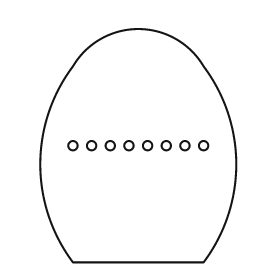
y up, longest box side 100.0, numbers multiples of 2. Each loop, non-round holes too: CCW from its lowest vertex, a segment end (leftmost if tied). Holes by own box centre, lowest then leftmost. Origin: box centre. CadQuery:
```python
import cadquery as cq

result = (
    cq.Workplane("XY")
    .moveTo(-28.0, -50.0)
    .lineTo(28.0, -50.0)
    .threePointArc((42.0, -8.0), (28.0, 34.0))
    .threePointArc((0.0, 50.0), (-28.0, 34.0))
    .threePointArc((-42.0, -8.0), (-28.0, -50.0))
    .close()
    .moveTo(-28.0, 0.0)
    .circle(2.0)
    .moveTo(-20.0, 0.0)
    .circle(2.0)
    .moveTo(-12.0, 0.0)
    .circle(2.0)
    .moveTo(-4.0, 0.0)
    .circle(2.0)
    .moveTo(4.0, 0.0)
    .circle(2.0)
    .moveTo(12.0, 0.0)
    .circle(2.0)
    .moveTo(20.0, 0.0)
    .circle(2.0)
    .moveTo(28.0, 0.0)
    .circle(2.0)
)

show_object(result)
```